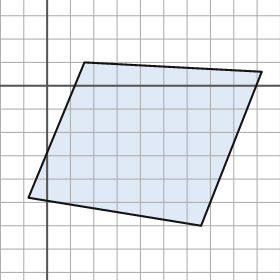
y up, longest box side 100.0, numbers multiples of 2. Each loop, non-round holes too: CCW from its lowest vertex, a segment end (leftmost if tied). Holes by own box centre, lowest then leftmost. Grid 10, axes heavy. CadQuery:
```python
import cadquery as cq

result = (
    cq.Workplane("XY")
    .moveTo(66.0, -60.0)
    .lineTo(92.0, 6.0)
    .lineTo(16.0, 10.0)
    .lineTo(-8.0, -48.0)
    .close()
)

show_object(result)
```